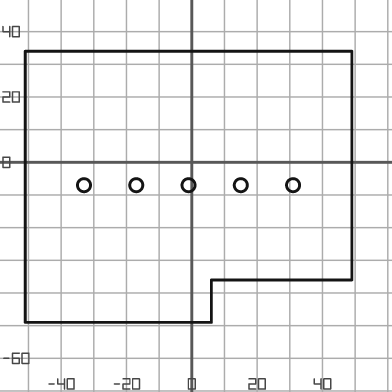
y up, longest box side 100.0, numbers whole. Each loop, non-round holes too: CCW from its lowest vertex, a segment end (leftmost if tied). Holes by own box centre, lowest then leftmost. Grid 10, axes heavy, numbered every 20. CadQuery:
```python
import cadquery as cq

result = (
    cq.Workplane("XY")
    .moveTo(-51.0, -49.0)
    .lineTo(6.0, -49.0)
    .lineTo(6.0, -36.0)
    .lineTo(49.0, -36.0)
    .lineTo(49.0, 34.0)
    .lineTo(-51.0, 34.0)
    .close()
    .moveTo(-33.0, -7.0)
    .circle(2.0)
    .moveTo(-17.0, -7.0)
    .circle(2.0)
    .moveTo(-1.0, -7.0)
    .circle(2.0)
    .moveTo(15.0, -7.0)
    .circle(2.0)
    .moveTo(31.0, -7.0)
    .circle(2.0)
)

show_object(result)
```